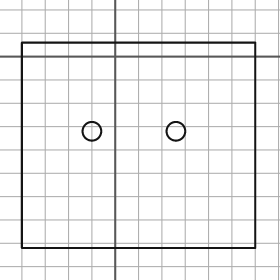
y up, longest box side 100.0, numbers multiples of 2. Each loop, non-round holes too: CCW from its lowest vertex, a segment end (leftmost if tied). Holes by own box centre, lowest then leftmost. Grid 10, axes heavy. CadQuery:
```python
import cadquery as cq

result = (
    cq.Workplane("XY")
    .moveTo(-40.0, -82.0)
    .lineTo(60.0, -82.0)
    .lineTo(60.0, 6.0)
    .lineTo(-40.0, 6.0)
    .close()
    .moveTo(-10.0, -32.0)
    .circle(4.0)
    .moveTo(26.0, -32.0)
    .circle(4.0)
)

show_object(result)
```